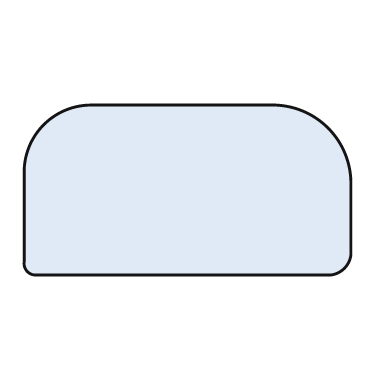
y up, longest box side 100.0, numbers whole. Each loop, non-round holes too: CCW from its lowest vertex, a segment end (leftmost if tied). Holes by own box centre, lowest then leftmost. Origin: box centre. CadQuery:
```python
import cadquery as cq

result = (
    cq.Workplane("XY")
    .moveTo(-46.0, -26.0)
    .lineTo(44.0, -26.0)
    .threePointArc((48.0, -24.0), (50.0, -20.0))
    .lineTo(50.0, 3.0)
    .threePointArc((43.0, 19.0), (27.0, 26.0))
    .lineTo(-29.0, 26.0)
    .threePointArc((-44.0, 20.0), (-50.0, 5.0))
    .lineTo(-50.0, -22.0)
    .threePointArc((-49.0, -25.0), (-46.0, -26.0))
    .close()
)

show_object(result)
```